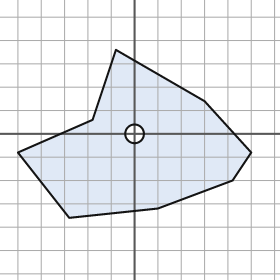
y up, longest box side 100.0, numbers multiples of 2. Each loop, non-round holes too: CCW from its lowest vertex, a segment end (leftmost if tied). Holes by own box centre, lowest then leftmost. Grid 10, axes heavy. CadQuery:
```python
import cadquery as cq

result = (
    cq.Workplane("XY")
    .moveTo(-28.0, -36.0)
    .lineTo(10.0, -32.0)
    .lineTo(42.0, -20.0)
    .lineTo(50.0, -8.0)
    .lineTo(30.0, 14.0)
    .lineTo(-8.0, 36.0)
    .lineTo(-18.0, 6.0)
    .lineTo(-50.0, -8.0)
    .close()
    .moveTo(0.0, 0.0)
    .circle(4.0)
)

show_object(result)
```